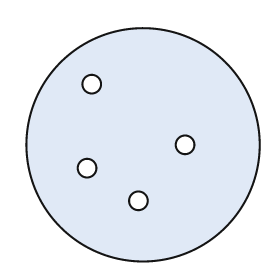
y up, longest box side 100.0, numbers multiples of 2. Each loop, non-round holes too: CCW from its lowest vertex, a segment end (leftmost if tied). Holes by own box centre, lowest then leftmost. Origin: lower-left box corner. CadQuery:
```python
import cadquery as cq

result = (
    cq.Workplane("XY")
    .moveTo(50.0, 50.0)
    .circle(50.0)
    .moveTo(48.0, 26.0)
    .circle(4.0)
    .moveTo(26.0, 40.0)
    .circle(4.0)
    .moveTo(68.0, 50.0)
    .circle(4.0)
    .moveTo(28.0, 76.0)
    .circle(4.0)
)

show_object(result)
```